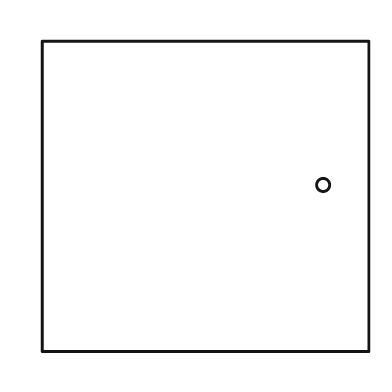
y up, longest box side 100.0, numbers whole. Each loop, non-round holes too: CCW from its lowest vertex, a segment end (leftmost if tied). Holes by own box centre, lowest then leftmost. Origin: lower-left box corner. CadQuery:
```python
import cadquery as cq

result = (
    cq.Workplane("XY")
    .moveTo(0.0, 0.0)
    .lineTo(100.0, 0.0)
    .lineTo(100.0, 95.0)
    .lineTo(0.0, 95.0)
    .close()
    .moveTo(86.0, 51.0)
    .circle(2.0)
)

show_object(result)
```